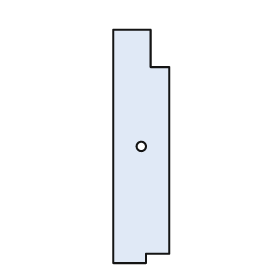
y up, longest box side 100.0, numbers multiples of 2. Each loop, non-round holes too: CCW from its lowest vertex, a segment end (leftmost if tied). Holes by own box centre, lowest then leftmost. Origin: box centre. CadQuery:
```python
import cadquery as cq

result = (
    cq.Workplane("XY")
    .moveTo(-12.0, -50.0)
    .lineTo(2.0, -50.0)
    .lineTo(2.0, -46.0)
    .lineTo(12.0, -46.0)
    .lineTo(12.0, 34.0)
    .lineTo(4.0, 34.0)
    .lineTo(4.0, 50.0)
    .lineTo(-12.0, 50.0)
    .close()
    .moveTo(0.0, 0.0)
    .circle(2.0)
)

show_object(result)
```